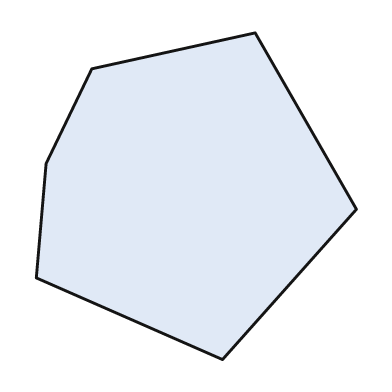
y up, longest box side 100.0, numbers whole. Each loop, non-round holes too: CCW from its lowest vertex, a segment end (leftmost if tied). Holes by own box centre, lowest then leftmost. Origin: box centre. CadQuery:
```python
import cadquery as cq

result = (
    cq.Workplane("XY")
    .moveTo(8.0, -50.0)
    .lineTo(49.0, -4.0)
    .lineTo(18.0, 50.0)
    .lineTo(-32.0, 39.0)
    .lineTo(-46.0, 10.0)
    .lineTo(-49.0, -25.0)
    .close()
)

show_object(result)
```